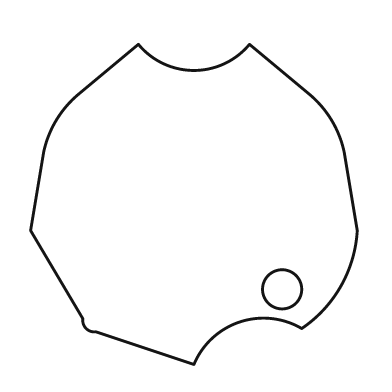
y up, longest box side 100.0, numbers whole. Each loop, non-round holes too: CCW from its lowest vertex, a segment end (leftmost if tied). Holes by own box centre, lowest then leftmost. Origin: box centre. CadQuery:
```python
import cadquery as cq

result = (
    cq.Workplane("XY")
    .moveTo(0.0, -49.0)
    .threePointArc((14.0, -36.0), (33.0, -38.0))
    .threePointArc((45.0, -25.0), (50.0, -8.0))
    .lineTo(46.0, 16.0)
    .threePointArc((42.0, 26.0), (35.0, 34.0))
    .lineTo(17.0, 49.0)
    .threePointArc((0.0, 41.0), (-17.0, 49.0))
    .lineTo(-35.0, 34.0)
    .threePointArc((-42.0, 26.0), (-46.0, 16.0))
    .lineTo(-50.0, -8.0)
    .lineTo(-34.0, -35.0)
    .threePointArc((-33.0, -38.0), (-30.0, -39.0))
    .close()
    .moveTo(27.0, -26.0)
    .circle(6.0)
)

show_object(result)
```